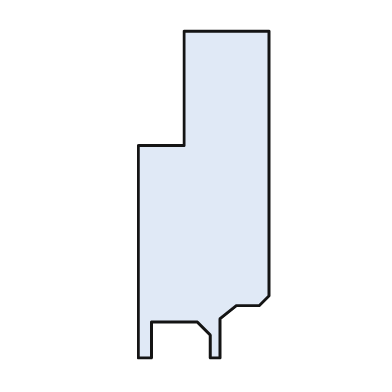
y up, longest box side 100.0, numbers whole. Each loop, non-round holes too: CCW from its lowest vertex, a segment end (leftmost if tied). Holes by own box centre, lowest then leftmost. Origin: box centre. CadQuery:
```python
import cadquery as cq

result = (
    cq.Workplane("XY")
    .moveTo(-20.0, -50.0)
    .lineTo(-16.0, -50.0)
    .lineTo(-16.0, -39.0)
    .lineTo(-2.0, -39.0)
    .lineTo(2.0, -43.0)
    .lineTo(2.0, -50.0)
    .lineTo(5.0, -50.0)
    .lineTo(5.0, -38.0)
    .lineTo(10.0, -34.0)
    .lineTo(17.0, -34.0)
    .lineTo(20.0, -31.0)
    .lineTo(20.0, 50.0)
    .lineTo(-6.0, 50.0)
    .lineTo(-6.0, 15.0)
    .lineTo(-20.0, 15.0)
    .close()
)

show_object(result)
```